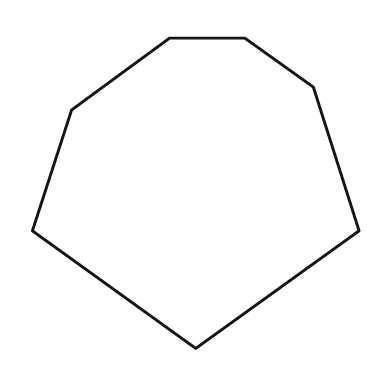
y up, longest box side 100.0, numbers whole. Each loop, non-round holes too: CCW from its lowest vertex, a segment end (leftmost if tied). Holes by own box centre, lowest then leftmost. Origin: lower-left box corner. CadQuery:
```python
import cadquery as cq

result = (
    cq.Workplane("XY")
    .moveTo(50.0, 0.0)
    .lineTo(100.0, 36.0)
    .lineTo(86.0, 80.0)
    .lineTo(65.0, 95.0)
    .lineTo(42.0, 95.0)
    .lineTo(12.0, 73.0)
    .lineTo(0.0, 36.0)
    .close()
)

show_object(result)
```